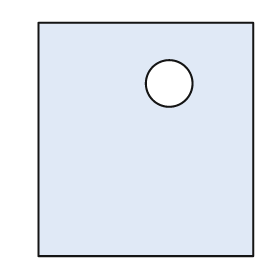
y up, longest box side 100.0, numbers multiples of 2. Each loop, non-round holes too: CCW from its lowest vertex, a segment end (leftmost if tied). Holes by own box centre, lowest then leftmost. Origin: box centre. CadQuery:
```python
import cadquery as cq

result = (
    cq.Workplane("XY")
    .moveTo(-46.0, -50.0)
    .lineTo(46.0, -50.0)
    .lineTo(46.0, 50.0)
    .lineTo(-46.0, 50.0)
    .close()
    .moveTo(10.0, 24.0)
    .circle(10.0)
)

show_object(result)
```